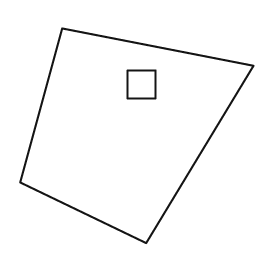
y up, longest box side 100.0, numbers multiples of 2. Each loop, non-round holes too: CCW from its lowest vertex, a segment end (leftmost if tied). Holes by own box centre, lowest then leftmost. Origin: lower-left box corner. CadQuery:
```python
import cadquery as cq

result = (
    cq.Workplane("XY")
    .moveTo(54.0, 0.0)
    .lineTo(100.0, 76.0)
    .lineTo(18.0, 92.0)
    .lineTo(0.0, 26.0)
    .close()
    .moveTo(46.0, 62.0)
    .lineTo(58.0, 62.0)
    .lineTo(58.0, 74.0)
    .lineTo(46.0, 74.0)
    .close()
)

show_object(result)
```